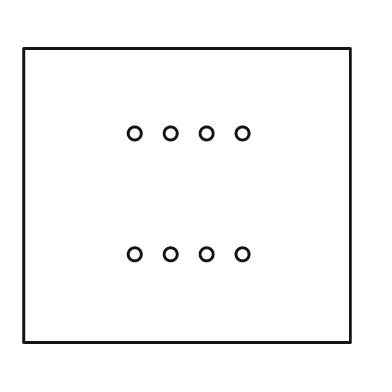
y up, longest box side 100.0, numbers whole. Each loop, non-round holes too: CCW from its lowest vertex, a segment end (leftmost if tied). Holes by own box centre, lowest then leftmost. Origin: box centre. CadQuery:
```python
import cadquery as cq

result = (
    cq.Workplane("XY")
    .moveTo(-50.0, -45.0)
    .lineTo(50.0, -45.0)
    .lineTo(50.0, 45.0)
    .lineTo(-50.0, 45.0)
    .close()
    .moveTo(-16.0, -18.0)
    .circle(2.0)
    .moveTo(-5.0, -18.0)
    .circle(2.0)
    .moveTo(6.0, -18.0)
    .circle(2.0)
    .moveTo(17.0, -18.0)
    .circle(2.0)
    .moveTo(-16.0, 19.0)
    .circle(2.0)
    .moveTo(-5.0, 19.0)
    .circle(2.0)
    .moveTo(6.0, 19.0)
    .circle(2.0)
    .moveTo(17.0, 19.0)
    .circle(2.0)
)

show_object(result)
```